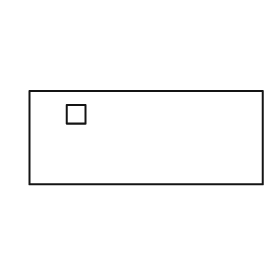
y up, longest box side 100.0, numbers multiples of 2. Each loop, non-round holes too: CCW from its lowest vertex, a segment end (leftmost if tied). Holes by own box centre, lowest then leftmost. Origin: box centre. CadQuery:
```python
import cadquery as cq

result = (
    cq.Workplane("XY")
    .moveTo(-50.0, -20.0)
    .lineTo(50.0, -20.0)
    .lineTo(50.0, 20.0)
    .lineTo(-50.0, 20.0)
    .close()
    .moveTo(-34.0, 6.0)
    .lineTo(-26.0, 6.0)
    .lineTo(-26.0, 14.0)
    .lineTo(-34.0, 14.0)
    .close()
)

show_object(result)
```